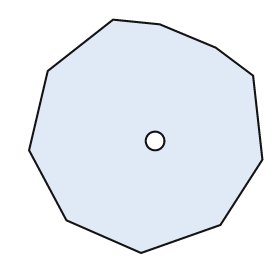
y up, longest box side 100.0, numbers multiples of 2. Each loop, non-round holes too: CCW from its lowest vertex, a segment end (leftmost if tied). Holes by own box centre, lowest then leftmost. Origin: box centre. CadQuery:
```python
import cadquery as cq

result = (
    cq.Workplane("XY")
    .moveTo(-2.0, -50.0)
    .lineTo(32.0, -38.0)
    .lineTo(50.0, -10.0)
    .lineTo(46.0, 26.0)
    .lineTo(30.0, 38.0)
    .lineTo(6.0, 48.0)
    .lineTo(-14.0, 50.0)
    .lineTo(-42.0, 28.0)
    .lineTo(-50.0, -6.0)
    .lineTo(-34.0, -36.0)
    .close()
    .moveTo(4.0, -2.0)
    .circle(4.0)
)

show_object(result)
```